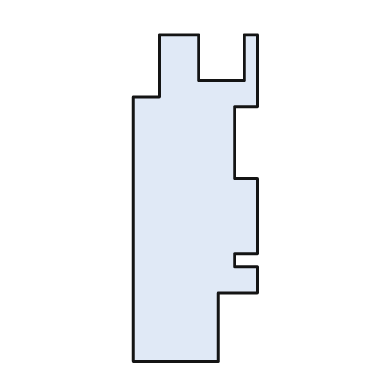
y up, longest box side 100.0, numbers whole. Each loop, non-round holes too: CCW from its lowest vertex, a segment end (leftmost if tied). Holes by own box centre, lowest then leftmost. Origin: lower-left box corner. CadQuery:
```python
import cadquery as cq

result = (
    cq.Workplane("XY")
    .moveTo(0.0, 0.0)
    .lineTo(26.0, 0.0)
    .lineTo(26.0, 21.0)
    .lineTo(38.0, 21.0)
    .lineTo(38.0, 29.0)
    .lineTo(31.0, 29.0)
    .lineTo(31.0, 33.0)
    .lineTo(38.0, 33.0)
    .lineTo(38.0, 56.0)
    .lineTo(31.0, 56.0)
    .lineTo(31.0, 78.0)
    .lineTo(38.0, 78.0)
    .lineTo(38.0, 100.0)
    .lineTo(34.0, 100.0)
    .lineTo(34.0, 86.0)
    .lineTo(20.0, 86.0)
    .lineTo(20.0, 100.0)
    .lineTo(8.0, 100.0)
    .lineTo(8.0, 81.0)
    .lineTo(0.0, 81.0)
    .close()
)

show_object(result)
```